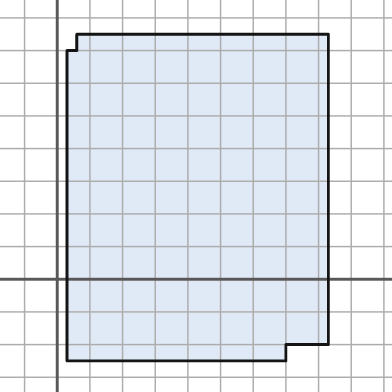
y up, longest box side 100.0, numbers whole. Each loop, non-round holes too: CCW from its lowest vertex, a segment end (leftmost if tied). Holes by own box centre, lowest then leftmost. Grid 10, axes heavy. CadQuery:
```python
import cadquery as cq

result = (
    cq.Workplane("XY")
    .moveTo(3.0, -25.0)
    .lineTo(70.0, -25.0)
    .lineTo(70.0, -20.0)
    .lineTo(83.0, -20.0)
    .lineTo(83.0, 75.0)
    .lineTo(6.0, 75.0)
    .lineTo(6.0, 70.0)
    .lineTo(3.0, 70.0)
    .close()
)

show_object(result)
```